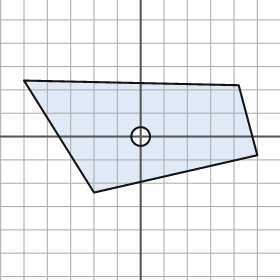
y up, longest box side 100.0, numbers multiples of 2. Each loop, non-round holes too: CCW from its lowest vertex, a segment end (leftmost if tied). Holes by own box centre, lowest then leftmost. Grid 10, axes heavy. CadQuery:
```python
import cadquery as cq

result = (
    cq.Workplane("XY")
    .moveTo(-20.0, -24.0)
    .lineTo(50.0, -8.0)
    .lineTo(42.0, 22.0)
    .lineTo(-50.0, 24.0)
    .close()
    .moveTo(0.0, 0.0)
    .circle(4.0)
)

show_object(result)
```